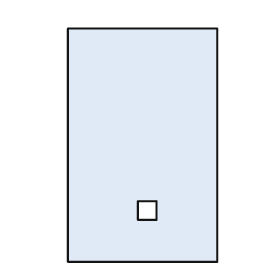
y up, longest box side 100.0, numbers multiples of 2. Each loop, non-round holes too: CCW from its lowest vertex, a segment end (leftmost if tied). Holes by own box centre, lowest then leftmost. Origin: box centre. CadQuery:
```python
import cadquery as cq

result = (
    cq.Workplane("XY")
    .moveTo(-32.0, -50.0)
    .lineTo(32.0, -50.0)
    .lineTo(32.0, 50.0)
    .lineTo(-32.0, 50.0)
    .close()
    .moveTo(-2.0, -32.0)
    .lineTo(6.0, -32.0)
    .lineTo(6.0, -24.0)
    .lineTo(-2.0, -24.0)
    .close()
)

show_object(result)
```